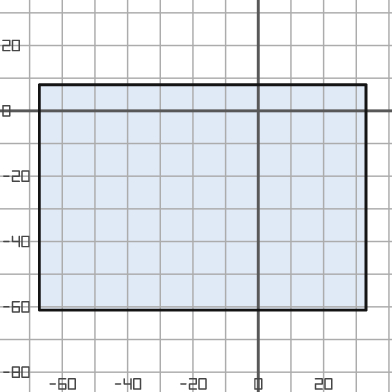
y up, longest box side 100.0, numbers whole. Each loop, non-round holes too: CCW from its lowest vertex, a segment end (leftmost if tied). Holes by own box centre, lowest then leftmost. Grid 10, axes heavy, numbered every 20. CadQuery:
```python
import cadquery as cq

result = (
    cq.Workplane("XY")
    .moveTo(-67.0, -61.0)
    .lineTo(33.0, -61.0)
    .lineTo(33.0, 8.0)
    .lineTo(-67.0, 8.0)
    .close()
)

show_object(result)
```